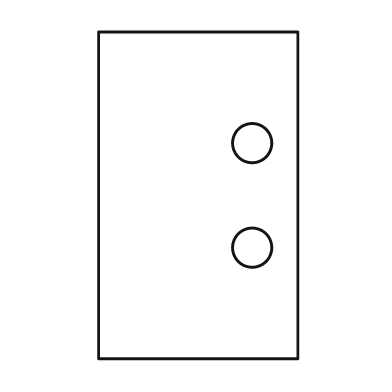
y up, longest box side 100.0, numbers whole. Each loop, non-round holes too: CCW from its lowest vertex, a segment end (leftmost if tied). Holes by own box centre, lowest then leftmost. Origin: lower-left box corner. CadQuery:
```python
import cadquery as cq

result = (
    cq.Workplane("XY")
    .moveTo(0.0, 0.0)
    .lineTo(61.0, 0.0)
    .lineTo(61.0, 100.0)
    .lineTo(0.0, 100.0)
    .close()
    .moveTo(47.0, 34.0)
    .circle(6.0)
    .moveTo(47.0, 66.0)
    .circle(6.0)
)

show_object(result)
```